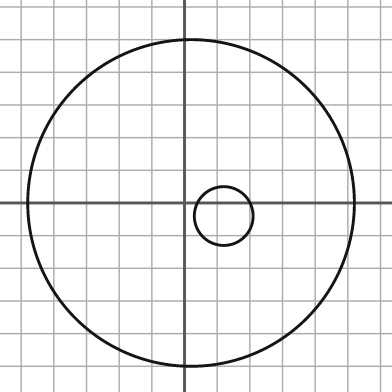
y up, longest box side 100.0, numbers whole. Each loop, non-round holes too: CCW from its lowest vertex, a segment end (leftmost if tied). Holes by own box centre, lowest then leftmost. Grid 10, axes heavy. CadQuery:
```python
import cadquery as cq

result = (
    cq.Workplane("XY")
    .moveTo(2.0, 0.0)
    .circle(50.0)
    .moveTo(12.0, -4.0)
    .circle(9.0)
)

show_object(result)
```